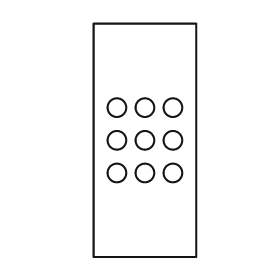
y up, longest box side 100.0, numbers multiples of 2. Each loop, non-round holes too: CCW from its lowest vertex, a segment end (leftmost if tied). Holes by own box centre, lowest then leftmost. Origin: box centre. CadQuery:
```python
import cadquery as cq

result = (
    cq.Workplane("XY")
    .moveTo(-22.0, -50.0)
    .lineTo(22.0, -50.0)
    .lineTo(22.0, 50.0)
    .lineTo(-22.0, 50.0)
    .close()
    .moveTo(-12.0, -14.0)
    .circle(4.0)
    .moveTo(0.0, -14.0)
    .circle(4.0)
    .moveTo(12.0, -14.0)
    .circle(4.0)
    .moveTo(-12.0, 0.0)
    .circle(4.0)
    .moveTo(0.0, 0.0)
    .circle(4.0)
    .moveTo(12.0, 0.0)
    .circle(4.0)
    .moveTo(-12.0, 14.0)
    .circle(4.0)
    .moveTo(0.0, 14.0)
    .circle(4.0)
    .moveTo(12.0, 14.0)
    .circle(4.0)
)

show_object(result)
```